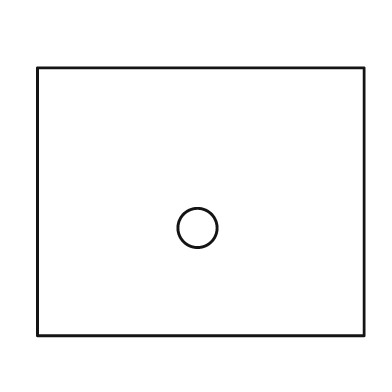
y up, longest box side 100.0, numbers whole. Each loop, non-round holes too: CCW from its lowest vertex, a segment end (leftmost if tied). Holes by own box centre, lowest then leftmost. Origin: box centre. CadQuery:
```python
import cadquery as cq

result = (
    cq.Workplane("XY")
    .moveTo(-50.0, -41.0)
    .lineTo(50.0, -41.0)
    .lineTo(50.0, 41.0)
    .lineTo(-50.0, 41.0)
    .close()
    .moveTo(-1.0, -8.0)
    .circle(6.0)
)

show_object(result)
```